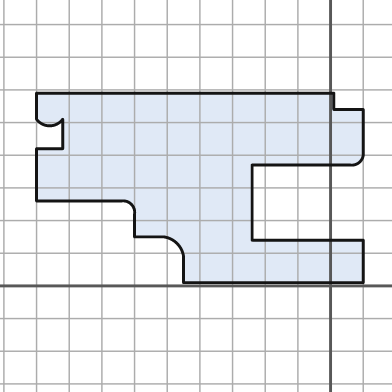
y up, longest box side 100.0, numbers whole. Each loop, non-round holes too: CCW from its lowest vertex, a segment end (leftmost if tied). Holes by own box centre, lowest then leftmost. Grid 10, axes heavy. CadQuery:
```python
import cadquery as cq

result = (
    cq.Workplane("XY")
    .moveTo(-45.0, 1.0)
    .lineTo(10.0, 1.0)
    .lineTo(10.0, 14.0)
    .lineTo(-24.0, 14.0)
    .lineTo(-24.0, 37.0)
    .lineTo(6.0, 37.0)
    .threePointArc((9.0, 38.0), (10.0, 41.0))
    .lineTo(10.0, 54.0)
    .lineTo(1.0, 54.0)
    .lineTo(1.0, 59.0)
    .lineTo(-90.0, 59.0)
    .lineTo(-90.0, 51.0)
    .threePointArc((-86.0, 49.0), (-82.0, 51.0))
    .lineTo(-82.0, 42.0)
    .lineTo(-90.0, 42.0)
    .lineTo(-90.0, 26.0)
    .lineTo(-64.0, 26.0)
    .threePointArc((-61.0, 25.0), (-60.0, 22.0))
    .lineTo(-60.0, 15.0)
    .lineTo(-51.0, 15.0)
    .threePointArc((-47.0, 13.0), (-45.0, 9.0))
    .close()
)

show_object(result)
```